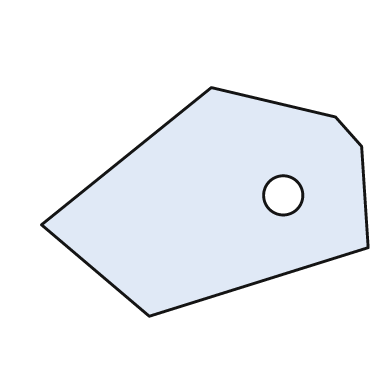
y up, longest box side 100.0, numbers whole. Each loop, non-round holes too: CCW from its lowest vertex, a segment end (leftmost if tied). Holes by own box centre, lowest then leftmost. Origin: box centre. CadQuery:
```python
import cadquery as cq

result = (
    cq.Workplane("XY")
    .moveTo(-17.0, -35.0)
    .lineTo(50.0, -14.0)
    .lineTo(48.0, 17.0)
    .lineTo(40.0, 26.0)
    .lineTo(2.0, 35.0)
    .lineTo(-50.0, -7.0)
    .close()
    .moveTo(24.0, 2.0)
    .circle(6.0)
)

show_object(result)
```